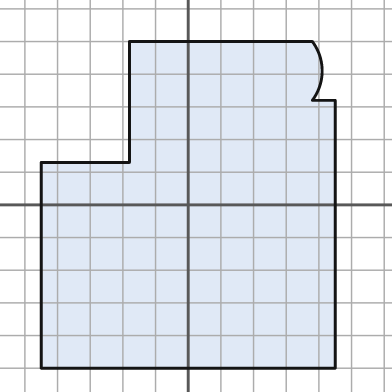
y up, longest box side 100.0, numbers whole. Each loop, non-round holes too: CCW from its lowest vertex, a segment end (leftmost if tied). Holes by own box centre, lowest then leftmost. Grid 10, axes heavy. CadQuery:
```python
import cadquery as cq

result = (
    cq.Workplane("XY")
    .moveTo(-45.0, -50.0)
    .lineTo(45.0, -50.0)
    .lineTo(45.0, 32.0)
    .lineTo(38.0, 32.0)
    .threePointArc((41.0, 41.0), (38.0, 50.0))
    .lineTo(-18.0, 50.0)
    .lineTo(-18.0, 13.0)
    .lineTo(-45.0, 13.0)
    .close()
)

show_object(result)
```